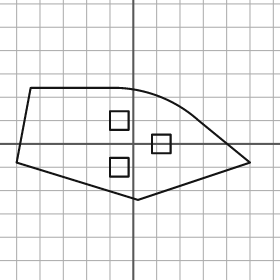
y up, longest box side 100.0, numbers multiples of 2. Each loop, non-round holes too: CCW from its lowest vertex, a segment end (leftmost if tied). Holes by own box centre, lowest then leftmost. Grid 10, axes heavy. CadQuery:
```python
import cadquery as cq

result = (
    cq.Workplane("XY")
    .moveTo(2.0, -24.0)
    .lineTo(50.0, -8.0)
    .lineTo(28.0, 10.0)
    .threePointArc((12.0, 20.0), (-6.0, 24.0))
    .lineTo(-44.0, 24.0)
    .lineTo(-50.0, -8.0)
    .close()
    .moveTo(-10.0, -14.0)
    .lineTo(-2.0, -14.0)
    .lineTo(-2.0, -6.0)
    .lineTo(-10.0, -6.0)
    .close()
    .moveTo(8.0, -4.0)
    .lineTo(16.0, -4.0)
    .lineTo(16.0, 4.0)
    .lineTo(8.0, 4.0)
    .close()
    .moveTo(-10.0, 6.0)
    .lineTo(-2.0, 6.0)
    .lineTo(-2.0, 14.0)
    .lineTo(-10.0, 14.0)
    .close()
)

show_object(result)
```